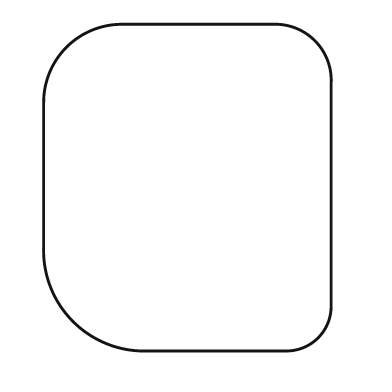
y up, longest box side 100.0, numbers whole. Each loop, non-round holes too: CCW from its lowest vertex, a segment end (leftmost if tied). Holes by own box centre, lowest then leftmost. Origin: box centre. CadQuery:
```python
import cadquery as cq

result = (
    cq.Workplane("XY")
    .moveTo(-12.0, -50.0)
    .lineTo(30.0, -50.0)
    .threePointArc((40.0, -46.0), (44.0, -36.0))
    .lineTo(44.0, 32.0)
    .threePointArc((39.0, 45.0), (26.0, 50.0))
    .lineTo(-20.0, 50.0)
    .threePointArc((-37.0, 43.0), (-44.0, 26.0))
    .lineTo(-44.0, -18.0)
    .threePointArc((-35.0, -41.0), (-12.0, -50.0))
    .close()
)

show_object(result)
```